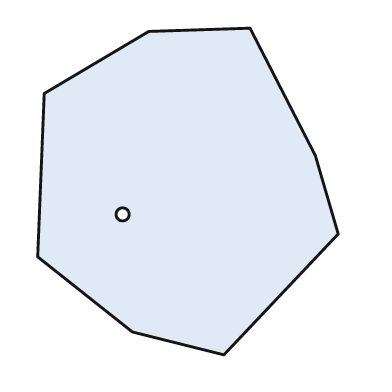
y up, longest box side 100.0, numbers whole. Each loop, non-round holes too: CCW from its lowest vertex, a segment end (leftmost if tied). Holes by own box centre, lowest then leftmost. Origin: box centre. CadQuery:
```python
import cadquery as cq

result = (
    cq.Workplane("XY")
    .moveTo(11.0, -50.0)
    .lineTo(46.0, -13.0)
    .lineTo(39.0, 11.0)
    .lineTo(19.0, 50.0)
    .lineTo(-12.0, 49.0)
    .lineTo(-44.0, 30.0)
    .lineTo(-46.0, -20.0)
    .lineTo(-17.0, -43.0)
    .close()
    .moveTo(-20.0, -7.0)
    .circle(2.0)
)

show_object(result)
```